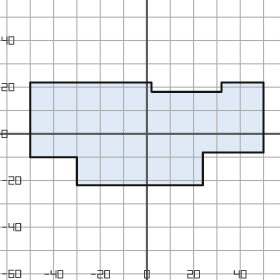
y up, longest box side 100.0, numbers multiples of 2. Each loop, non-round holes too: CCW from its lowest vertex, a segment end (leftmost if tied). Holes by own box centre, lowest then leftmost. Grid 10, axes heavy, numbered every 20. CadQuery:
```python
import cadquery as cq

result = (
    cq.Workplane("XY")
    .moveTo(-30.0, -22.0)
    .lineTo(24.0, -22.0)
    .lineTo(24.0, -8.0)
    .lineTo(50.0, -8.0)
    .lineTo(50.0, 22.0)
    .lineTo(32.0, 22.0)
    .lineTo(32.0, 18.0)
    .lineTo(2.0, 18.0)
    .lineTo(2.0, 22.0)
    .lineTo(-50.0, 22.0)
    .lineTo(-50.0, -10.0)
    .lineTo(-30.0, -10.0)
    .close()
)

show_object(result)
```